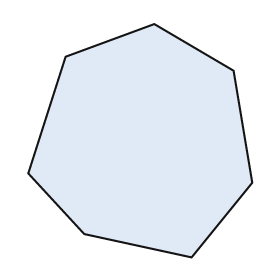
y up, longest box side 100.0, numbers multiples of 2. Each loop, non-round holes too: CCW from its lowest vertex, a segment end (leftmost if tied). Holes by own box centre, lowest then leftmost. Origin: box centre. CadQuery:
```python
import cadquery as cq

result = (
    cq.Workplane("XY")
    .moveTo(22.0, -50.0)
    .lineTo(48.0, -18.0)
    .lineTo(40.0, 30.0)
    .lineTo(6.0, 50.0)
    .lineTo(-32.0, 36.0)
    .lineTo(-48.0, -14.0)
    .lineTo(-24.0, -40.0)
    .close()
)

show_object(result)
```